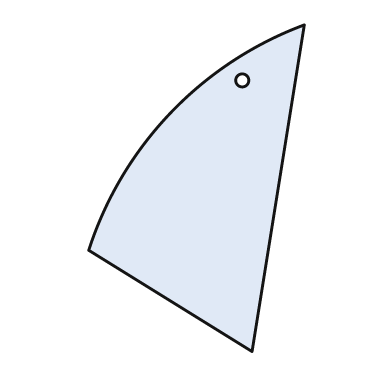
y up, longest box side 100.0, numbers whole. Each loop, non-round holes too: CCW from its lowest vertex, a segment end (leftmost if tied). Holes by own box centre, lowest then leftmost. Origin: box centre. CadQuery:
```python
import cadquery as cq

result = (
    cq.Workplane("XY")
    .moveTo(17.0, -50.0)
    .lineTo(33.0, 50.0)
    .threePointArc((-8.0, 23.0), (-33.0, -19.0))
    .close()
    .moveTo(14.0, 33.0)
    .circle(2.0)
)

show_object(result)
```